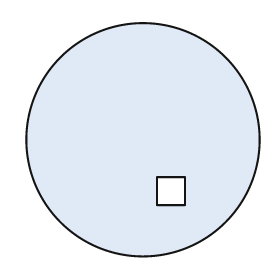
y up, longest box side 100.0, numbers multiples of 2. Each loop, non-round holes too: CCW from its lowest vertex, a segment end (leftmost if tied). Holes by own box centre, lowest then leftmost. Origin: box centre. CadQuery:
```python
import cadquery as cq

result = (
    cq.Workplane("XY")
    .moveTo(0.0, 0.0)
    .circle(50.0)
    .moveTo(6.0, -28.0)
    .lineTo(18.0, -28.0)
    .lineTo(18.0, -16.0)
    .lineTo(6.0, -16.0)
    .close()
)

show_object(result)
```